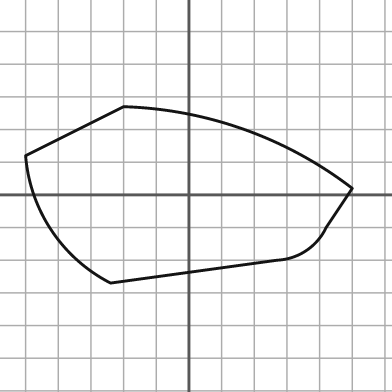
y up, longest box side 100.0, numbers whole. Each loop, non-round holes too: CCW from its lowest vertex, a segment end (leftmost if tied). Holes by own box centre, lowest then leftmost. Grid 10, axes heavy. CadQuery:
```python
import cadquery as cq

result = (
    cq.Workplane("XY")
    .moveTo(-24.0, -27.0)
    .lineTo(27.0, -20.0)
    .threePointArc((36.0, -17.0), (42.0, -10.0))
    .lineTo(50.0, 2.0)
    .threePointArc((17.0, 20.0), (-20.0, 27.0))
    .lineTo(-50.0, 12.0)
    .threePointArc((-42.0, -11.0), (-24.0, -27.0))
    .close()
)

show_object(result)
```